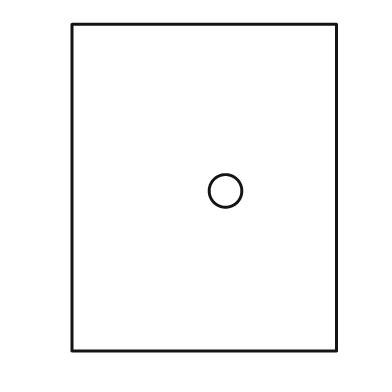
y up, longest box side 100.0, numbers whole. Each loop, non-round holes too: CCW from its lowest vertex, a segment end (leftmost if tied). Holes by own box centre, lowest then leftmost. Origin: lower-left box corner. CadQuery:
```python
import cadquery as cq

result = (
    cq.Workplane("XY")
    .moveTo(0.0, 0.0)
    .lineTo(81.0, 0.0)
    .lineTo(81.0, 100.0)
    .lineTo(0.0, 100.0)
    .close()
    .moveTo(47.0, 49.0)
    .circle(5.0)
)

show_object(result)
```